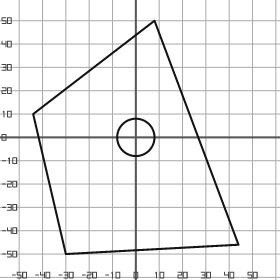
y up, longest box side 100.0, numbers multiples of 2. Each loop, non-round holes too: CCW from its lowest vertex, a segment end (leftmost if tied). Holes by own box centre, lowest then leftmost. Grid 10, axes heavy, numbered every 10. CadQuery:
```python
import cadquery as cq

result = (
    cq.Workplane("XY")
    .moveTo(-30.0, -50.0)
    .lineTo(44.0, -46.0)
    .lineTo(8.0, 50.0)
    .lineTo(-44.0, 10.0)
    .close()
    .moveTo(0.0, 0.0)
    .circle(8.0)
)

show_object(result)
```